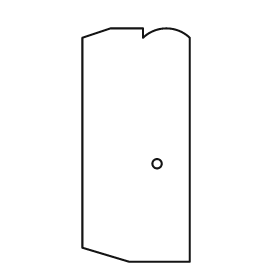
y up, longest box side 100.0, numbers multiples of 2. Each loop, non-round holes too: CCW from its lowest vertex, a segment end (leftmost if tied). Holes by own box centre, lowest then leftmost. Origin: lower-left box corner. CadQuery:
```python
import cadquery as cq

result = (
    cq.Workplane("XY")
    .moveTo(20.0, 0.0)
    .lineTo(46.0, 0.0)
    .lineTo(46.0, 96.0)
    .threePointArc((36.0, 100.0), (26.0, 96.0))
    .lineTo(26.0, 100.0)
    .lineTo(12.0, 100.0)
    .lineTo(0.0, 96.0)
    .lineTo(0.0, 6.0)
    .close()
    .moveTo(32.0, 42.0)
    .circle(2.0)
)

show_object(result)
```